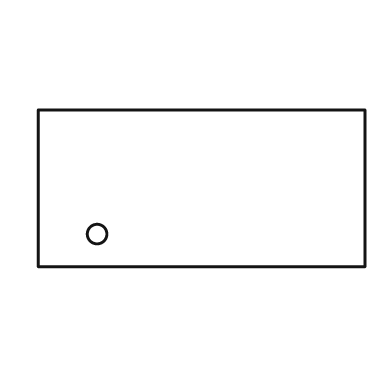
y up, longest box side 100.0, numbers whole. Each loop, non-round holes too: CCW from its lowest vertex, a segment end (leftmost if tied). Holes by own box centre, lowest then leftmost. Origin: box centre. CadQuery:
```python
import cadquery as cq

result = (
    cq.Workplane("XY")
    .moveTo(-50.0, -24.0)
    .lineTo(50.0, -24.0)
    .lineTo(50.0, 24.0)
    .lineTo(-50.0, 24.0)
    .close()
    .moveTo(-32.0, -14.0)
    .circle(3.0)
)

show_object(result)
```